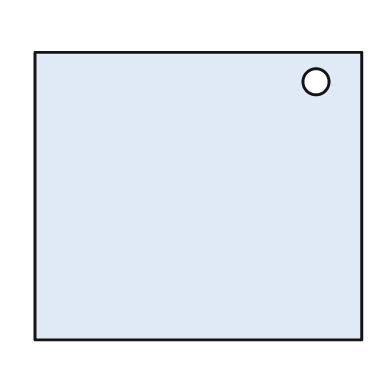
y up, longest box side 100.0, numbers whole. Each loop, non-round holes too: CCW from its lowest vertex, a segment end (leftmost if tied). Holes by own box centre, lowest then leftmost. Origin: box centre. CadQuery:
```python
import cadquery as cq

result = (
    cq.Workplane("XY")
    .moveTo(-50.0, -44.0)
    .lineTo(50.0, -44.0)
    .lineTo(50.0, 44.0)
    .lineTo(-50.0, 44.0)
    .close()
    .moveTo(36.0, 35.0)
    .circle(4.0)
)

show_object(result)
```